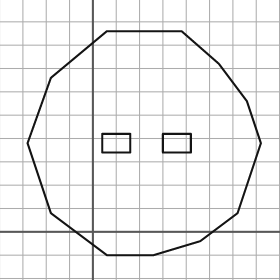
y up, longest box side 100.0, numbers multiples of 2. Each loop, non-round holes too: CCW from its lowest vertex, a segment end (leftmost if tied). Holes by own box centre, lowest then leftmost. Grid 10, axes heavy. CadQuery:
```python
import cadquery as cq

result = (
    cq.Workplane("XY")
    .moveTo(6.0, -10.0)
    .lineTo(26.0, -10.0)
    .lineTo(46.0, -4.0)
    .lineTo(62.0, 8.0)
    .lineTo(72.0, 38.0)
    .lineTo(66.0, 56.0)
    .lineTo(54.0, 72.0)
    .lineTo(38.0, 86.0)
    .lineTo(6.0, 86.0)
    .lineTo(-18.0, 66.0)
    .lineTo(-28.0, 38.0)
    .lineTo(-18.0, 8.0)
    .close()
    .moveTo(4.0, 34.0)
    .lineTo(16.0, 34.0)
    .lineTo(16.0, 42.0)
    .lineTo(4.0, 42.0)
    .close()
    .moveTo(30.0, 34.0)
    .lineTo(42.0, 34.0)
    .lineTo(42.0, 42.0)
    .lineTo(30.0, 42.0)
    .close()
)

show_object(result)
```